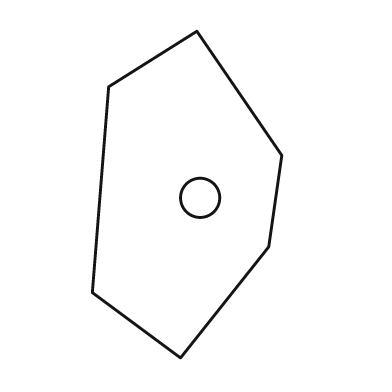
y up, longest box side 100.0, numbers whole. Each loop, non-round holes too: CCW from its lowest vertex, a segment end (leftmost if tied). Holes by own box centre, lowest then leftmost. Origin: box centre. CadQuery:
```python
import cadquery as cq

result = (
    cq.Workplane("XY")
    .moveTo(-2.0, -50.0)
    .lineTo(25.0, -16.0)
    .lineTo(29.0, 12.0)
    .lineTo(3.0, 50.0)
    .lineTo(-24.0, 33.0)
    .lineTo(-29.0, -30.0)
    .close()
    .moveTo(4.0, -1.0)
    .circle(6.0)
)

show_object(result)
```